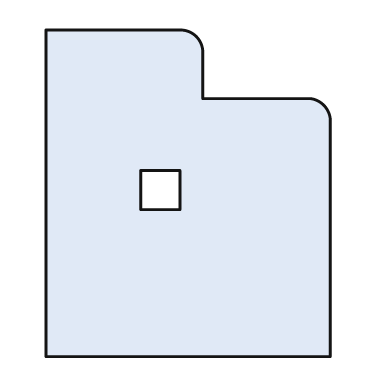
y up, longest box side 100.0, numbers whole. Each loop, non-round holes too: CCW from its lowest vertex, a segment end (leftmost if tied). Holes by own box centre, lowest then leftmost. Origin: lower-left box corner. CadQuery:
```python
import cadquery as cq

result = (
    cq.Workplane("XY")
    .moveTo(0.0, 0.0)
    .lineTo(87.0, 0.0)
    .lineTo(87.0, 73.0)
    .threePointArc((85.0, 77.0), (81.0, 79.0))
    .lineTo(48.0, 79.0)
    .lineTo(48.0, 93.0)
    .threePointArc((46.0, 98.0), (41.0, 100.0))
    .lineTo(0.0, 100.0)
    .close()
    .moveTo(29.0, 45.0)
    .lineTo(41.0, 45.0)
    .lineTo(41.0, 57.0)
    .lineTo(29.0, 57.0)
    .close()
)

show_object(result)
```